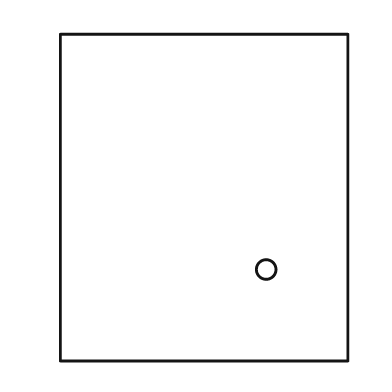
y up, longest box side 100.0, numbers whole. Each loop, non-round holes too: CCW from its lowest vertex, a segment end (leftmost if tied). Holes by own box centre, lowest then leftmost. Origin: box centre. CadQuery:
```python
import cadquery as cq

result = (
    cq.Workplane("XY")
    .moveTo(-44.0, -50.0)
    .lineTo(44.0, -50.0)
    .lineTo(44.0, 50.0)
    .lineTo(-44.0, 50.0)
    .close()
    .moveTo(19.0, -22.0)
    .circle(3.0)
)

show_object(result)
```